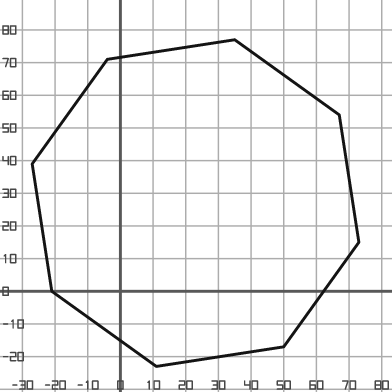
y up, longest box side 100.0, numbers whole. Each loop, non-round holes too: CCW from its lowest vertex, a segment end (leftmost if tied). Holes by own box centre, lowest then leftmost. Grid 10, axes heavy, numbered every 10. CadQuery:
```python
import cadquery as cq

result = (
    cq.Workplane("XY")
    .moveTo(11.0, -23.0)
    .lineTo(50.0, -17.0)
    .lineTo(73.0, 15.0)
    .lineTo(67.0, 54.0)
    .lineTo(35.0, 77.0)
    .lineTo(-4.0, 71.0)
    .lineTo(-27.0, 39.0)
    .lineTo(-21.0, 0.0)
    .close()
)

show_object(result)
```